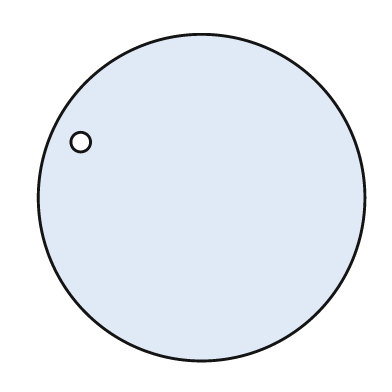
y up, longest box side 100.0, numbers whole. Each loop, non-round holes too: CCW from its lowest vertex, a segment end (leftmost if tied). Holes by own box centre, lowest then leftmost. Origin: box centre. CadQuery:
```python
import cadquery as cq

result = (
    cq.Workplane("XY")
    .moveTo(0.0, 0.0)
    .circle(50.0)
    .moveTo(-37.0, 17.0)
    .circle(3.0)
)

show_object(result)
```